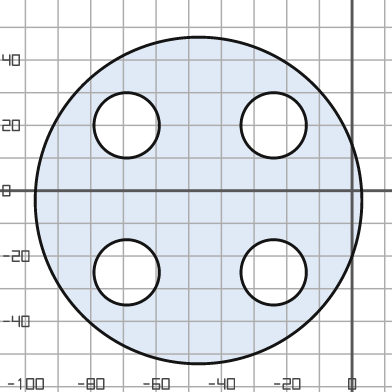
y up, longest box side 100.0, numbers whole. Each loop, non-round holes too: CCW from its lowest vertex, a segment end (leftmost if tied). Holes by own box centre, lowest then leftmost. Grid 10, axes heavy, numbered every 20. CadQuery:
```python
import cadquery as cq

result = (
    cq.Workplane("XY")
    .moveTo(-47.0, -3.0)
    .circle(50.0)
    .moveTo(-69.0, -25.0)
    .circle(10.0)
    .moveTo(-24.0, -25.0)
    .circle(10.0)
    .moveTo(-69.0, 20.0)
    .circle(10.0)
    .moveTo(-24.0, 20.0)
    .circle(10.0)
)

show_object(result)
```